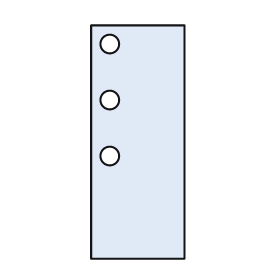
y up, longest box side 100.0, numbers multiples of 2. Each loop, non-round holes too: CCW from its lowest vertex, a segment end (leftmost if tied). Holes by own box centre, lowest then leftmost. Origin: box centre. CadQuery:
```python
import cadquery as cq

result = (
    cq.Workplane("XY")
    .moveTo(-20.0, -50.0)
    .lineTo(20.0, -50.0)
    .lineTo(20.0, 50.0)
    .lineTo(-20.0, 50.0)
    .close()
    .moveTo(-12.0, -6.0)
    .circle(4.0)
    .moveTo(-12.0, 18.0)
    .circle(4.0)
    .moveTo(-12.0, 42.0)
    .circle(4.0)
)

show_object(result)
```